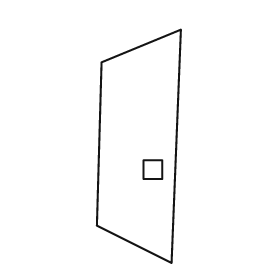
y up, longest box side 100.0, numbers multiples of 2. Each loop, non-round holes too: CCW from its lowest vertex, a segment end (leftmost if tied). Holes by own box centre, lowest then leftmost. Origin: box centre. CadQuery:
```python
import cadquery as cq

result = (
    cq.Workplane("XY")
    .moveTo(14.0, -50.0)
    .lineTo(18.0, 50.0)
    .lineTo(-16.0, 36.0)
    .lineTo(-18.0, -34.0)
    .close()
    .moveTo(2.0, -14.0)
    .lineTo(10.0, -14.0)
    .lineTo(10.0, -6.0)
    .lineTo(2.0, -6.0)
    .close()
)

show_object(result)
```